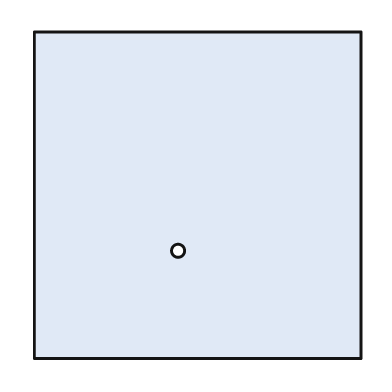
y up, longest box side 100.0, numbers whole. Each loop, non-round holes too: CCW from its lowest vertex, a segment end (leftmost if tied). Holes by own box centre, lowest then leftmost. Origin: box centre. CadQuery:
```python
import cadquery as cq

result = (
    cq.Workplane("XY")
    .moveTo(-50.0, -50.0)
    .lineTo(50.0, -50.0)
    .lineTo(50.0, 50.0)
    .lineTo(-50.0, 50.0)
    .close()
    .moveTo(-6.0, -17.0)
    .circle(2.0)
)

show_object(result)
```